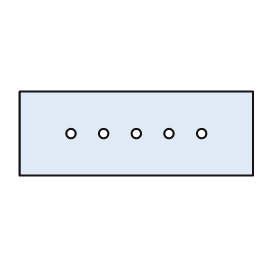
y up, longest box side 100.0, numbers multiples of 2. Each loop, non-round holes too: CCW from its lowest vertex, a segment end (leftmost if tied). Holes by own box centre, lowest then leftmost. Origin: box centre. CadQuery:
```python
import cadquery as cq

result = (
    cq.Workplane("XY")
    .moveTo(-50.0, -18.0)
    .lineTo(50.0, -18.0)
    .lineTo(50.0, 18.0)
    .lineTo(-50.0, 18.0)
    .close()
    .moveTo(-28.0, 0.0)
    .circle(2.0)
    .moveTo(-14.0, 0.0)
    .circle(2.0)
    .moveTo(0.0, 0.0)
    .circle(2.0)
    .moveTo(14.0, 0.0)
    .circle(2.0)
    .moveTo(28.0, 0.0)
    .circle(2.0)
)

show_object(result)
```